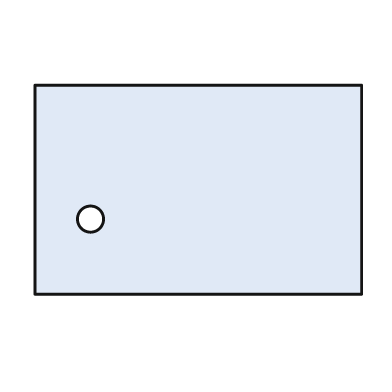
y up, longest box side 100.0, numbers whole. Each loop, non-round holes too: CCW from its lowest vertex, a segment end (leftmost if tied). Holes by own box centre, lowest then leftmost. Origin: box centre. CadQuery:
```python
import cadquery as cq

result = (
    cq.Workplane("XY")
    .moveTo(-50.0, -32.0)
    .lineTo(50.0, -32.0)
    .lineTo(50.0, 32.0)
    .lineTo(-50.0, 32.0)
    .close()
    .moveTo(-33.0, -9.0)
    .circle(4.0)
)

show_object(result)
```